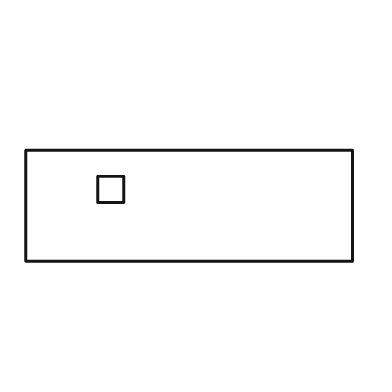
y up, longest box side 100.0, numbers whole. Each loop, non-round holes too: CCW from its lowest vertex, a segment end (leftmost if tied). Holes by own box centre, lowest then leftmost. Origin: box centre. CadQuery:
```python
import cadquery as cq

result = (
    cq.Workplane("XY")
    .moveTo(-50.0, -17.0)
    .lineTo(50.0, -17.0)
    .lineTo(50.0, 17.0)
    .lineTo(-50.0, 17.0)
    .close()
    .moveTo(-28.0, 1.0)
    .lineTo(-20.0, 1.0)
    .lineTo(-20.0, 9.0)
    .lineTo(-28.0, 9.0)
    .close()
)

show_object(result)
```